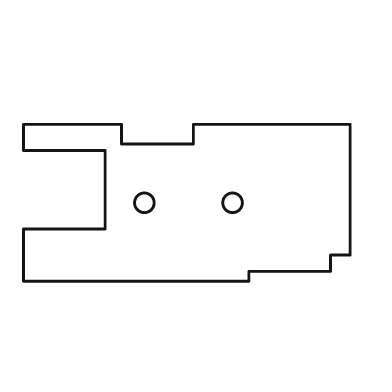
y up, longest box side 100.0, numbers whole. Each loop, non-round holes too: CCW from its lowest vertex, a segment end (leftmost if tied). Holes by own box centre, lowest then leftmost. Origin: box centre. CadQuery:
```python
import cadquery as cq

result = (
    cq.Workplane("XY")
    .moveTo(-50.0, -24.0)
    .lineTo(19.0, -24.0)
    .lineTo(19.0, -21.0)
    .lineTo(44.0, -21.0)
    .lineTo(44.0, -16.0)
    .lineTo(50.0, -16.0)
    .lineTo(50.0, 24.0)
    .lineTo(2.0, 24.0)
    .lineTo(2.0, 18.0)
    .lineTo(-20.0, 18.0)
    .lineTo(-20.0, 24.0)
    .lineTo(-50.0, 24.0)
    .lineTo(-50.0, 16.0)
    .lineTo(-25.0, 16.0)
    .lineTo(-25.0, -8.0)
    .lineTo(-50.0, -8.0)
    .close()
    .moveTo(-13.0, 0.0)
    .circle(3.0)
    .moveTo(14.0, 0.0)
    .circle(3.0)
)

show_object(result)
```